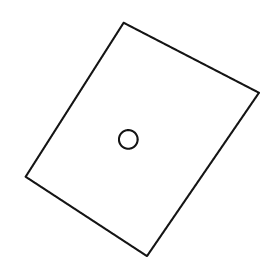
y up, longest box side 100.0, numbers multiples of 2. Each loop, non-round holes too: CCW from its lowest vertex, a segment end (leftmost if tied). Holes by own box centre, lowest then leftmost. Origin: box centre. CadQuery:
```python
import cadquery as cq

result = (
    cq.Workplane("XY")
    .moveTo(2.0, -50.0)
    .lineTo(50.0, 20.0)
    .lineTo(-8.0, 50.0)
    .lineTo(-50.0, -16.0)
    .close()
    .moveTo(-6.0, 0.0)
    .circle(4.0)
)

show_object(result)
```